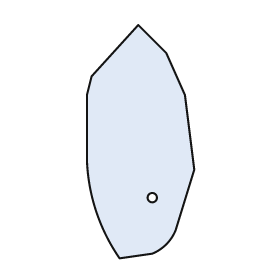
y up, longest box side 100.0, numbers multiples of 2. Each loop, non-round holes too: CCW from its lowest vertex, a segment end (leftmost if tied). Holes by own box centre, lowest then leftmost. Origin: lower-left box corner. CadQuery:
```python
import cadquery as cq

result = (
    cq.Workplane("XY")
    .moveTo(14.0, 0.0)
    .lineTo(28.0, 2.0)
    .threePointArc((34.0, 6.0), (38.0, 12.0))
    .lineTo(46.0, 38.0)
    .lineTo(42.0, 70.0)
    .lineTo(34.0, 88.0)
    .lineTo(22.0, 100.0)
    .lineTo(2.0, 78.0)
    .lineTo(0.0, 70.0)
    .lineTo(0.0, 42.0)
    .threePointArc((4.0, 20.0), (14.0, 0.0))
    .close()
    .moveTo(28.0, 26.0)
    .circle(2.0)
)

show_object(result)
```